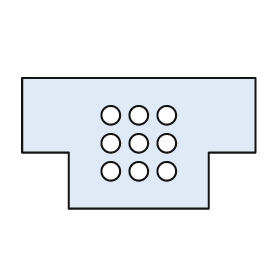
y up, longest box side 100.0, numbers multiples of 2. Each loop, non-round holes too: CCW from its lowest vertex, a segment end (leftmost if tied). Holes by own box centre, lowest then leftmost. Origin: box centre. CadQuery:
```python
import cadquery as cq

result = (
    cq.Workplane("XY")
    .moveTo(-30.0, -28.0)
    .lineTo(30.0, -28.0)
    .lineTo(30.0, -4.0)
    .lineTo(50.0, -4.0)
    .lineTo(50.0, 28.0)
    .lineTo(-50.0, 28.0)
    .lineTo(-50.0, -4.0)
    .lineTo(-30.0, -4.0)
    .close()
    .moveTo(-12.0, -12.0)
    .circle(4.0)
    .moveTo(0.0, -12.0)
    .circle(4.0)
    .moveTo(12.0, -12.0)
    .circle(4.0)
    .moveTo(-12.0, 0.0)
    .circle(4.0)
    .moveTo(0.0, 0.0)
    .circle(4.0)
    .moveTo(12.0, 0.0)
    .circle(4.0)
    .moveTo(-12.0, 12.0)
    .circle(4.0)
    .moveTo(0.0, 12.0)
    .circle(4.0)
    .moveTo(12.0, 12.0)
    .circle(4.0)
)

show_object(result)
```